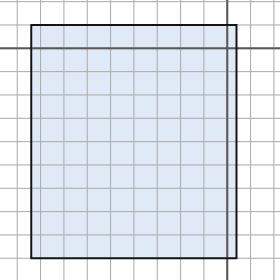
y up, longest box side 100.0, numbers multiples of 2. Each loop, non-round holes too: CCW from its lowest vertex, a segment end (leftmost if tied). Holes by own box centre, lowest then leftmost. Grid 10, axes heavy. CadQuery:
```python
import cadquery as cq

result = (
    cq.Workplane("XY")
    .moveTo(-84.0, -90.0)
    .lineTo(4.0, -90.0)
    .lineTo(4.0, 10.0)
    .lineTo(-84.0, 10.0)
    .close()
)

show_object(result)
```